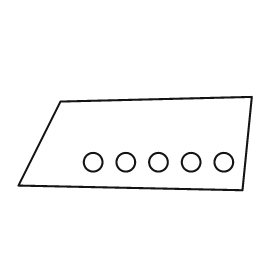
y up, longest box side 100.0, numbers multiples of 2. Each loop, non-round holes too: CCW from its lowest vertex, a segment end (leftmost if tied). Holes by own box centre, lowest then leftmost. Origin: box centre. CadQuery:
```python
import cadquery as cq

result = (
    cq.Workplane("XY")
    .moveTo(46.0, -20.0)
    .lineTo(50.0, 20.0)
    .lineTo(-32.0, 18.0)
    .lineTo(-50.0, -18.0)
    .close()
    .moveTo(-18.0, -8.0)
    .circle(4.0)
    .moveTo(-4.0, -8.0)
    .circle(4.0)
    .moveTo(10.0, -8.0)
    .circle(4.0)
    .moveTo(24.0, -8.0)
    .circle(4.0)
    .moveTo(38.0, -8.0)
    .circle(4.0)
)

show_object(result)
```